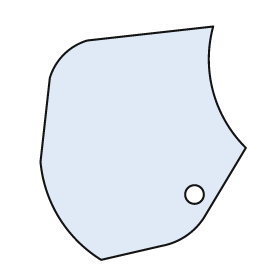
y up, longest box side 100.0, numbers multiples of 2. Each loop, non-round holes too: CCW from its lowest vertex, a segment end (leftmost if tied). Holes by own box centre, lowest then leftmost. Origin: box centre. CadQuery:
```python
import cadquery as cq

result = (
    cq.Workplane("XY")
    .moveTo(-18.0, -50.0)
    .lineTo(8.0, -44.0)
    .threePointArc((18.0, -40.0), (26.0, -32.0))
    .lineTo(44.0, -2.0)
    .threePointArc((30.0, 22.0), (30.0, 50.0))
    .lineTo(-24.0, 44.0)
    .threePointArc((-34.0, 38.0), (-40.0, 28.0))
    .lineTo(-44.0, -8.0)
    .threePointArc((-36.0, -32.0), (-18.0, -50.0))
    .close()
    .moveTo(22.0, -22.0)
    .circle(4.0)
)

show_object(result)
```